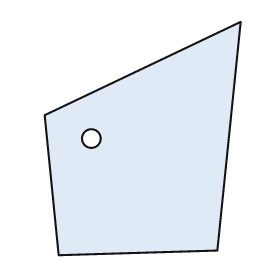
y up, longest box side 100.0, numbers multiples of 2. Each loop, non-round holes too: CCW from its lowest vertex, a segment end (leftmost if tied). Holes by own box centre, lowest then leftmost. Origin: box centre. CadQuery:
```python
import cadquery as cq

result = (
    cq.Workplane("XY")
    .moveTo(-36.0, -50.0)
    .lineTo(32.0, -48.0)
    .lineTo(42.0, 50.0)
    .lineTo(-42.0, 10.0)
    .close()
    .moveTo(-22.0, 0.0)
    .circle(4.0)
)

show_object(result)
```